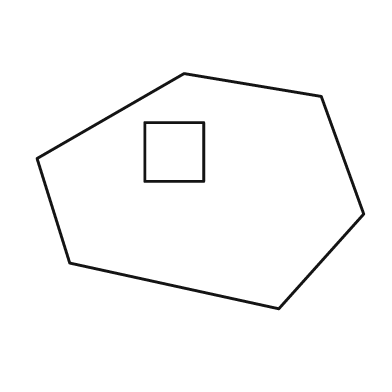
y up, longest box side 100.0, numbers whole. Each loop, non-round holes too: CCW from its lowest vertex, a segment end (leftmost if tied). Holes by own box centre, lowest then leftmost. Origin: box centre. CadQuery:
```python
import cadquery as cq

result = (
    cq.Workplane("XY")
    .moveTo(24.0, -36.0)
    .lineTo(50.0, -7.0)
    .lineTo(37.0, 29.0)
    .lineTo(-5.0, 36.0)
    .lineTo(-50.0, 10.0)
    .lineTo(-40.0, -22.0)
    .close()
    .moveTo(-17.0, 3.0)
    .lineTo(1.0, 3.0)
    .lineTo(1.0, 21.0)
    .lineTo(-17.0, 21.0)
    .close()
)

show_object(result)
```